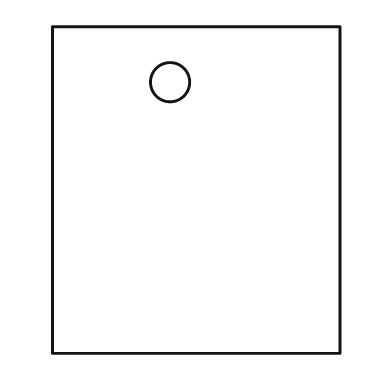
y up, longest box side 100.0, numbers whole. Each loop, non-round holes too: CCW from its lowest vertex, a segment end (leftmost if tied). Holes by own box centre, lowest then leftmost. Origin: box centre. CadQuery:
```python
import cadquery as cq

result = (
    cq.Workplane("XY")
    .moveTo(-44.0, -50.0)
    .lineTo(44.0, -50.0)
    .lineTo(44.0, 50.0)
    .lineTo(-44.0, 50.0)
    .close()
    .moveTo(-8.0, 33.0)
    .circle(6.0)
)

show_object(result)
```